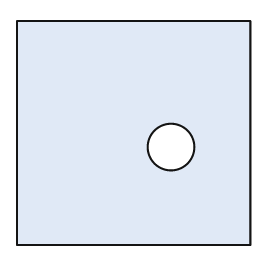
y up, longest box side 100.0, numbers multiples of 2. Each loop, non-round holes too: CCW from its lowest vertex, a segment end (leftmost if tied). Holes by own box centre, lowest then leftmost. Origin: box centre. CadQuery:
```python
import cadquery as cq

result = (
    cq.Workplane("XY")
    .moveTo(-50.0, -48.0)
    .lineTo(50.0, -48.0)
    .lineTo(50.0, 48.0)
    .lineTo(-50.0, 48.0)
    .close()
    .moveTo(16.0, -6.0)
    .circle(10.0)
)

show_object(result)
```